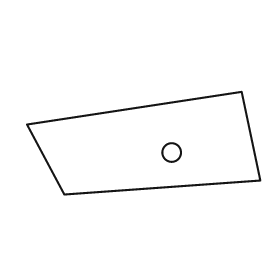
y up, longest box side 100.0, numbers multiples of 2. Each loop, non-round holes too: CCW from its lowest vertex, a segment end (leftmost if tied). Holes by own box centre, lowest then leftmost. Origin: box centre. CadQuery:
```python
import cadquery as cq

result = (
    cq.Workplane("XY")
    .moveTo(-34.0, -22.0)
    .lineTo(50.0, -16.0)
    .lineTo(42.0, 22.0)
    .lineTo(-50.0, 8.0)
    .close()
    .moveTo(12.0, -4.0)
    .circle(4.0)
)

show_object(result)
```